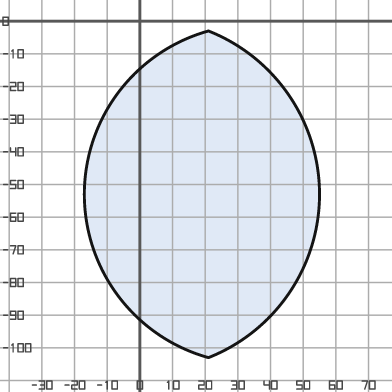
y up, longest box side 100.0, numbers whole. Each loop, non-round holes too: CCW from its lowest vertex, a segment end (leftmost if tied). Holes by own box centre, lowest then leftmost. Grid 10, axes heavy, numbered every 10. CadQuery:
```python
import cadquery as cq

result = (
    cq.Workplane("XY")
    .moveTo(21.0, -103.0)
    .threePointArc((55.0, -53.0), (21.0, -3.0))
    .threePointArc((-17.0, -53.0), (21.0, -103.0))
    .close()
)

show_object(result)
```